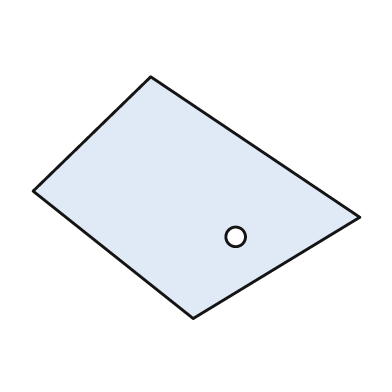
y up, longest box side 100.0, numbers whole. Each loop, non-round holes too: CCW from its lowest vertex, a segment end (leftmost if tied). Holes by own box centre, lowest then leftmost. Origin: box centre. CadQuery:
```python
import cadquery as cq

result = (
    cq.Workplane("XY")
    .moveTo(-1.0, -37.0)
    .lineTo(50.0, -6.0)
    .lineTo(-14.0, 37.0)
    .lineTo(-50.0, 2.0)
    .close()
    .moveTo(12.0, -12.0)
    .circle(3.0)
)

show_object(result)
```